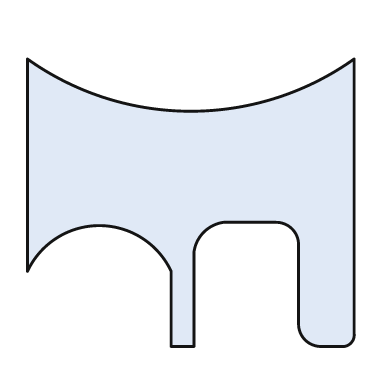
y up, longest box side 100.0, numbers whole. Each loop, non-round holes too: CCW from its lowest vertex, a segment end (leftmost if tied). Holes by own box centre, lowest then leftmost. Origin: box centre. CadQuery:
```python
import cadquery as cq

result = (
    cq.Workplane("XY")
    .moveTo(-6.0, -44.0)
    .lineTo(1.0, -44.0)
    .lineTo(1.0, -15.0)
    .threePointArc((4.0, -9.0), (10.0, -6.0))
    .lineTo(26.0, -6.0)
    .threePointArc((31.0, -8.0), (33.0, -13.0))
    .lineTo(33.0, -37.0)
    .threePointArc((35.0, -42.0), (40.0, -44.0))
    .lineTo(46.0, -44.0)
    .threePointArc((49.0, -43.0), (50.0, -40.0))
    .lineTo(50.0, 44.0)
    .threePointArc((0.0, 28.0), (-50.0, 44.0))
    .lineTo(-50.0, -21.0)
    .threePointArc((-28.0, -7.0), (-6.0, -21.0))
    .close()
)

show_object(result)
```